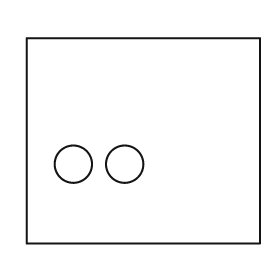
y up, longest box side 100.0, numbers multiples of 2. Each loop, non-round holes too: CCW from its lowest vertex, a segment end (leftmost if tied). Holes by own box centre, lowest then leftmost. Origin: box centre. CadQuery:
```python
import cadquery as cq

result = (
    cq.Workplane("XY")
    .moveTo(-50.0, -44.0)
    .lineTo(50.0, -44.0)
    .lineTo(50.0, 44.0)
    .lineTo(-50.0, 44.0)
    .close()
    .moveTo(-30.0, -10.0)
    .circle(8.0)
    .moveTo(-8.0, -10.0)
    .circle(8.0)
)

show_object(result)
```